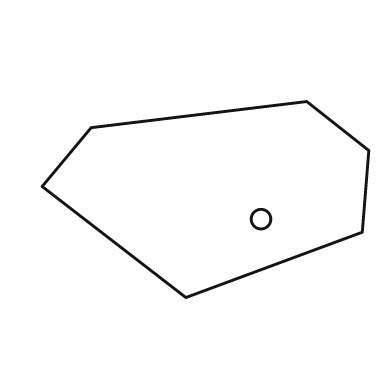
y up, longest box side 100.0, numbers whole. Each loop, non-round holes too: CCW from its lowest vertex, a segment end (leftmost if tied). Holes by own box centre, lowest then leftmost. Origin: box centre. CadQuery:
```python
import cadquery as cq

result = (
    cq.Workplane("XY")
    .moveTo(-6.0, -30.0)
    .lineTo(48.0, -10.0)
    .lineTo(50.0, 15.0)
    .lineTo(31.0, 30.0)
    .lineTo(-35.0, 22.0)
    .lineTo(-50.0, 4.0)
    .close()
    .moveTo(17.0, -6.0)
    .circle(3.0)
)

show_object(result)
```